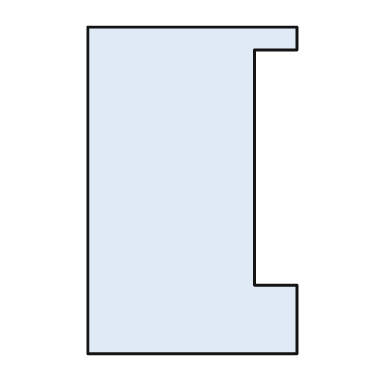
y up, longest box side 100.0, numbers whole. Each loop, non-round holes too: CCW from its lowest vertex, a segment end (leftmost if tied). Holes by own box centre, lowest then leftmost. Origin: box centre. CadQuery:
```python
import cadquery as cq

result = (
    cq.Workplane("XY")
    .moveTo(-32.0, -50.0)
    .lineTo(32.0, -50.0)
    .lineTo(32.0, -29.0)
    .lineTo(19.0, -29.0)
    .lineTo(19.0, 43.0)
    .lineTo(32.0, 43.0)
    .lineTo(32.0, 50.0)
    .lineTo(-32.0, 50.0)
    .close()
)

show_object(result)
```